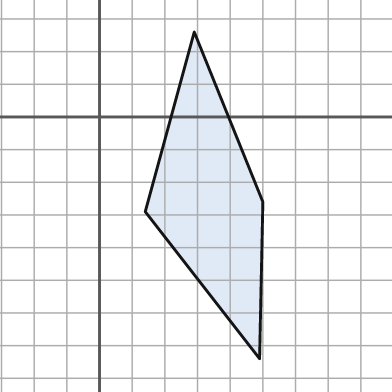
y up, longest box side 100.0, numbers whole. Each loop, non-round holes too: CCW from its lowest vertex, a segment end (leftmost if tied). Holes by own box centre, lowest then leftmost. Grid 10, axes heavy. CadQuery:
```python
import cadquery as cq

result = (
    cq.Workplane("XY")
    .moveTo(49.0, -74.0)
    .lineTo(50.0, -26.0)
    .lineTo(29.0, 26.0)
    .lineTo(14.0, -29.0)
    .close()
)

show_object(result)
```